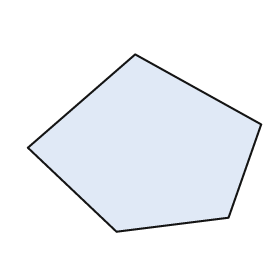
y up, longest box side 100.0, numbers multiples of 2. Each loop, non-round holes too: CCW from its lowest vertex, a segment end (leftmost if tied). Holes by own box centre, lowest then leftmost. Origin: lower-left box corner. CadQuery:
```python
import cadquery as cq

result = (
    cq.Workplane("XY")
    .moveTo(38.0, 0.0)
    .lineTo(86.0, 6.0)
    .lineTo(100.0, 46.0)
    .lineTo(46.0, 76.0)
    .lineTo(0.0, 36.0)
    .close()
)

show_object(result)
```